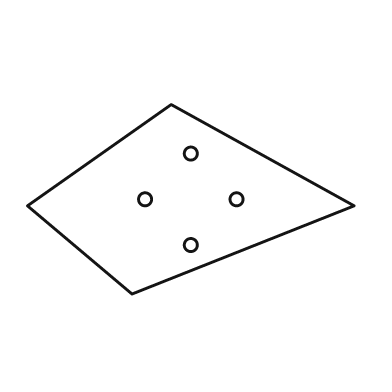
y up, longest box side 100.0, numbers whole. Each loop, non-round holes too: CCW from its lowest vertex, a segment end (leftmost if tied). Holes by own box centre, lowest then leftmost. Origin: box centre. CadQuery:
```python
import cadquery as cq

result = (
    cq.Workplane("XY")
    .moveTo(-18.0, -29.0)
    .lineTo(50.0, -2.0)
    .lineTo(-6.0, 29.0)
    .lineTo(-50.0, -2.0)
    .close()
    .moveTo(0.0, -14.0)
    .circle(2.0)
    .moveTo(-14.0, 0.0)
    .circle(2.0)
    .moveTo(14.0, 0.0)
    .circle(2.0)
    .moveTo(0.0, 14.0)
    .circle(2.0)
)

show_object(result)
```